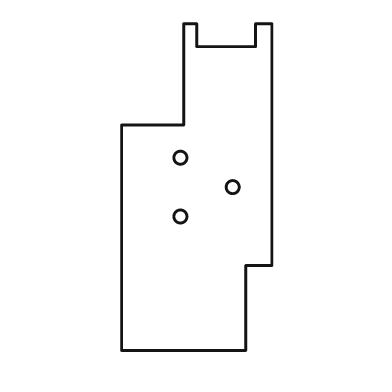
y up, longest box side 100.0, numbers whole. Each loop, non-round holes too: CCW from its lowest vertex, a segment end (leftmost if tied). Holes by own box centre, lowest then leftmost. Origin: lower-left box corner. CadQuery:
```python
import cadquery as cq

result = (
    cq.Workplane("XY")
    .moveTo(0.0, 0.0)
    .lineTo(38.0, 0.0)
    .lineTo(38.0, 26.0)
    .lineTo(46.0, 26.0)
    .lineTo(46.0, 100.0)
    .lineTo(41.0, 100.0)
    .lineTo(41.0, 93.0)
    .lineTo(23.0, 93.0)
    .lineTo(23.0, 100.0)
    .lineTo(19.0, 100.0)
    .lineTo(19.0, 69.0)
    .lineTo(0.0, 69.0)
    .close()
    .moveTo(18.0, 41.0)
    .circle(2.0)
    .moveTo(34.0, 50.0)
    .circle(2.0)
    .moveTo(18.0, 59.0)
    .circle(2.0)
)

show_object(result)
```